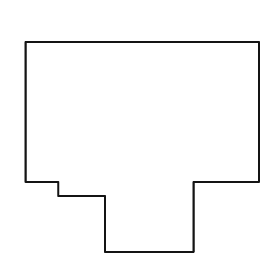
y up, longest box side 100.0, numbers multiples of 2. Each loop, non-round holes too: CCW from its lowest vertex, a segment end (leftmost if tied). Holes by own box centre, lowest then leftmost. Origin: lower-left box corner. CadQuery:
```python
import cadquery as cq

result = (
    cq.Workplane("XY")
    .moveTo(34.0, 0.0)
    .lineTo(72.0, 0.0)
    .lineTo(72.0, 30.0)
    .lineTo(100.0, 30.0)
    .lineTo(100.0, 90.0)
    .lineTo(0.0, 90.0)
    .lineTo(0.0, 30.0)
    .lineTo(14.0, 30.0)
    .lineTo(14.0, 24.0)
    .lineTo(34.0, 24.0)
    .close()
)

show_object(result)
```